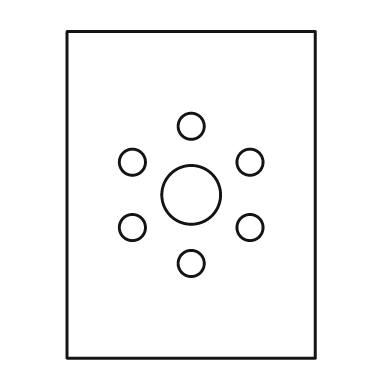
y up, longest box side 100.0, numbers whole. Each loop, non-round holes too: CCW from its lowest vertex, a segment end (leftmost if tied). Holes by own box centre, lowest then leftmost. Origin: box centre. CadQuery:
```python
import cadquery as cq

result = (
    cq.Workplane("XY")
    .moveTo(-38.0, -50.0)
    .lineTo(38.0, -50.0)
    .lineTo(38.0, 50.0)
    .lineTo(-38.0, 50.0)
    .close()
    .moveTo(0.0, -21.0)
    .circle(4.0)
    .moveTo(-18.0, -10.0)
    .circle(4.0)
    .moveTo(18.0, -10.0)
    .circle(4.0)
    .moveTo(0.0, 0.0)
    .circle(9.0)
    .moveTo(-18.0, 10.0)
    .circle(4.0)
    .moveTo(18.0, 10.0)
    .circle(4.0)
    .moveTo(0.0, 21.0)
    .circle(4.0)
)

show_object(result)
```